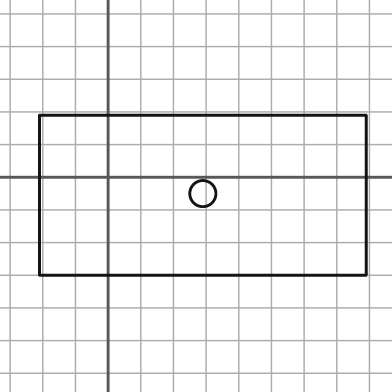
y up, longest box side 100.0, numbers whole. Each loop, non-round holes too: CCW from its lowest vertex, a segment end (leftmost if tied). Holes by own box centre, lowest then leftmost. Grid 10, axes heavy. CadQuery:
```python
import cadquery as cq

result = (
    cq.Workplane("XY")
    .moveTo(-21.0, -30.0)
    .lineTo(79.0, -30.0)
    .lineTo(79.0, 19.0)
    .lineTo(-21.0, 19.0)
    .close()
    .moveTo(29.0, -5.0)
    .circle(4.0)
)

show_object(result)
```